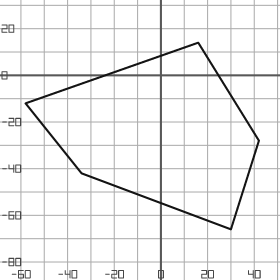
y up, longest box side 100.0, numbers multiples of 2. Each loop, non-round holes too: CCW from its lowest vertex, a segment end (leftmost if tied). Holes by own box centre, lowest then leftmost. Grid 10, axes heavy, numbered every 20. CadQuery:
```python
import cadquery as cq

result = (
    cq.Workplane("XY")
    .moveTo(30.0, -66.0)
    .lineTo(42.0, -28.0)
    .lineTo(16.0, 14.0)
    .lineTo(-58.0, -12.0)
    .lineTo(-34.0, -42.0)
    .close()
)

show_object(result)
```